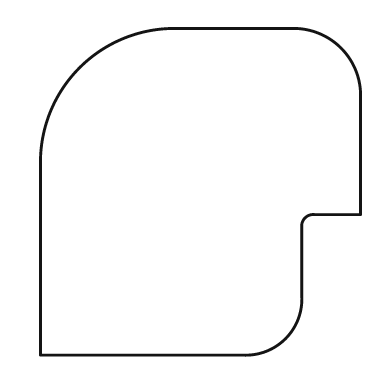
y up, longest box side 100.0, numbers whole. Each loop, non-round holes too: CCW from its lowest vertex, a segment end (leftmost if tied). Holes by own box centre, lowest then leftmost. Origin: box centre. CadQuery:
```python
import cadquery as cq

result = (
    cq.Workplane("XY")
    .moveTo(-49.0, -50.0)
    .lineTo(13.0, -50.0)
    .threePointArc((26.0, -45.0), (31.0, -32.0))
    .lineTo(31.0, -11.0)
    .threePointArc((32.0, -8.0), (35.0, -7.0))
    .lineTo(49.0, -7.0)
    .lineTo(49.0, 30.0)
    .threePointArc((43.0, 44.0), (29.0, 50.0))
    .lineTo(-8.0, 50.0)
    .threePointArc((-37.0, 38.0), (-49.0, 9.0))
    .close()
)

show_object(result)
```